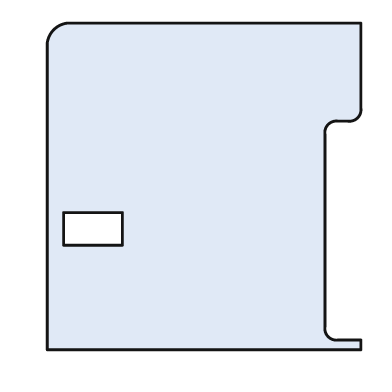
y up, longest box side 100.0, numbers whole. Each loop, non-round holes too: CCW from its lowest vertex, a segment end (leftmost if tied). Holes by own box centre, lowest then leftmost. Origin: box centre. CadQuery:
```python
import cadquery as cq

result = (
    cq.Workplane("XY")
    .moveTo(-48.0, -50.0)
    .lineTo(48.0, -50.0)
    .lineTo(48.0, -47.0)
    .lineTo(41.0, -47.0)
    .threePointArc((38.0, -46.0), (37.0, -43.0))
    .lineTo(37.0, 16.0)
    .threePointArc((38.0, 19.0), (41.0, 20.0))
    .lineTo(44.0, 20.0)
    .threePointArc((47.0, 21.0), (48.0, 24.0))
    .lineTo(48.0, 50.0)
    .lineTo(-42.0, 50.0)
    .threePointArc((-46.0, 48.0), (-48.0, 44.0))
    .close()
    .moveTo(-43.0, -18.0)
    .lineTo(-25.0, -18.0)
    .lineTo(-25.0, -8.0)
    .lineTo(-43.0, -8.0)
    .close()
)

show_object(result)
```